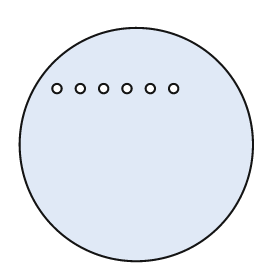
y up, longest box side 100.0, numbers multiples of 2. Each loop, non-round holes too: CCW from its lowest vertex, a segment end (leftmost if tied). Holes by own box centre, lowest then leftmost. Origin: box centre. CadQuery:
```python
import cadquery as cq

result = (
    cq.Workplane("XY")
    .moveTo(0.0, 0.0)
    .circle(50.0)
    .moveTo(-34.0, 24.0)
    .circle(2.0)
    .moveTo(-24.0, 24.0)
    .circle(2.0)
    .moveTo(-14.0, 24.0)
    .circle(2.0)
    .moveTo(-4.0, 24.0)
    .circle(2.0)
    .moveTo(6.0, 24.0)
    .circle(2.0)
    .moveTo(16.0, 24.0)
    .circle(2.0)
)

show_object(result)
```